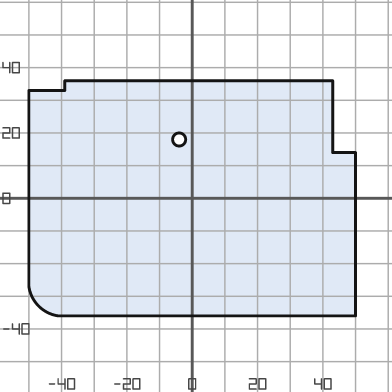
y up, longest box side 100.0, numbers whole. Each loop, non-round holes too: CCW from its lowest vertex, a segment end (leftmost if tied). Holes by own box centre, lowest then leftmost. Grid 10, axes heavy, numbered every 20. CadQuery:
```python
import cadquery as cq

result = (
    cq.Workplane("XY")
    .moveTo(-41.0, -36.0)
    .lineTo(50.0, -36.0)
    .lineTo(50.0, 14.0)
    .lineTo(43.0, 14.0)
    .lineTo(43.0, 36.0)
    .lineTo(-39.0, 36.0)
    .lineTo(-39.0, 33.0)
    .lineTo(-50.0, 33.0)
    .lineTo(-50.0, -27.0)
    .threePointArc((-47.0, -33.0), (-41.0, -36.0))
    .close()
    .moveTo(-4.0, 18.0)
    .circle(2.0)
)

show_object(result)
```